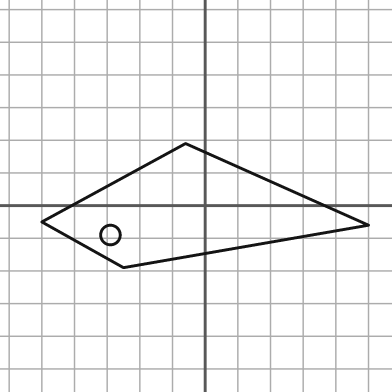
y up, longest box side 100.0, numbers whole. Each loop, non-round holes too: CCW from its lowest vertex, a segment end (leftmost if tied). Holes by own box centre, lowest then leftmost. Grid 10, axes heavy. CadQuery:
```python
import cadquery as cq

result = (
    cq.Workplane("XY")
    .moveTo(-25.0, -19.0)
    .lineTo(50.0, -6.0)
    .lineTo(-6.0, 19.0)
    .lineTo(-50.0, -5.0)
    .close()
    .moveTo(-29.0, -9.0)
    .circle(3.0)
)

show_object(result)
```